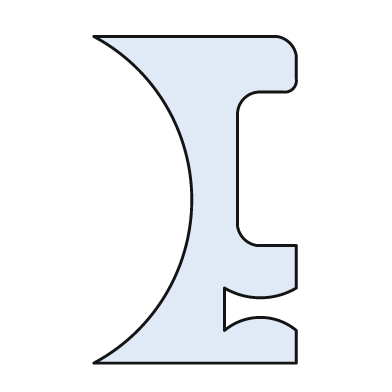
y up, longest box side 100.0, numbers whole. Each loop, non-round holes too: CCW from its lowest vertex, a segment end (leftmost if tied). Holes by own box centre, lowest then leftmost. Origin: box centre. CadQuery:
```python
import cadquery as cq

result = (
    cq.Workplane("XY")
    .moveTo(-31.0, -50.0)
    .lineTo(31.0, -50.0)
    .lineTo(31.0, -40.0)
    .threePointArc((20.0, -36.0), (9.0, -40.0))
    .lineTo(9.0, -27.0)
    .threePointArc((20.0, -30.0), (31.0, -27.0))
    .lineTo(31.0, -14.0)
    .lineTo(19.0, -14.0)
    .threePointArc((15.0, -12.0), (13.0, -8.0))
    .lineTo(13.0, 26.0)
    .threePointArc((15.0, 31.0), (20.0, 33.0))
    .lineTo(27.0, 33.0)
    .threePointArc((30.0, 34.0), (31.0, 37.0))
    .lineTo(31.0, 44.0)
    .threePointArc((29.0, 48.0), (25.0, 50.0))
    .lineTo(-31.0, 50.0)
    .threePointArc((-1.0, 0.0), (-31.0, -50.0))
    .close()
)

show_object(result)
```